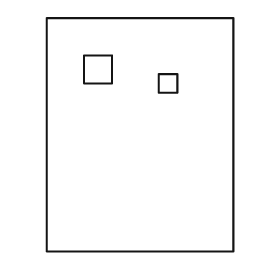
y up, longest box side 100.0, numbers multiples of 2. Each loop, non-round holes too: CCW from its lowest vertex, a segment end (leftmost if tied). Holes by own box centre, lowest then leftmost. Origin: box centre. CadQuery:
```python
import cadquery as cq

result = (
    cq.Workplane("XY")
    .moveTo(-40.0, -50.0)
    .lineTo(40.0, -50.0)
    .lineTo(40.0, 50.0)
    .lineTo(-40.0, 50.0)
    .close()
    .moveTo(8.0, 18.0)
    .lineTo(16.0, 18.0)
    .lineTo(16.0, 26.0)
    .lineTo(8.0, 26.0)
    .close()
    .moveTo(-24.0, 22.0)
    .lineTo(-12.0, 22.0)
    .lineTo(-12.0, 34.0)
    .lineTo(-24.0, 34.0)
    .close()
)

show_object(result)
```